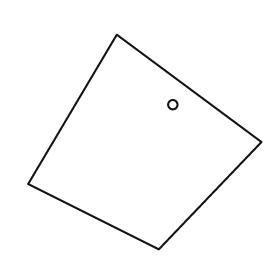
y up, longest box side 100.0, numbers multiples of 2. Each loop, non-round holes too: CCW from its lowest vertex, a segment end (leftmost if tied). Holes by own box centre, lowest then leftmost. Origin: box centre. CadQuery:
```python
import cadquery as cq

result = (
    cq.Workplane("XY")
    .moveTo(6.0, -46.0)
    .lineTo(50.0, 0.0)
    .lineTo(-12.0, 46.0)
    .lineTo(-50.0, -18.0)
    .close()
    .moveTo(12.0, 16.0)
    .circle(2.0)
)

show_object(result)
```